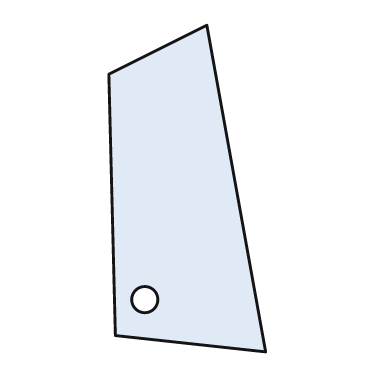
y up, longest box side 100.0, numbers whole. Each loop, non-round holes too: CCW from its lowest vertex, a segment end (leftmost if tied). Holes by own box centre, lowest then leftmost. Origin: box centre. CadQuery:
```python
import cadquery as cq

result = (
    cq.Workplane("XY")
    .moveTo(24.0, -50.0)
    .lineTo(6.0, 50.0)
    .lineTo(-24.0, 35.0)
    .lineTo(-22.0, -45.0)
    .close()
    .moveTo(-13.0, -34.0)
    .circle(4.0)
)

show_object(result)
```